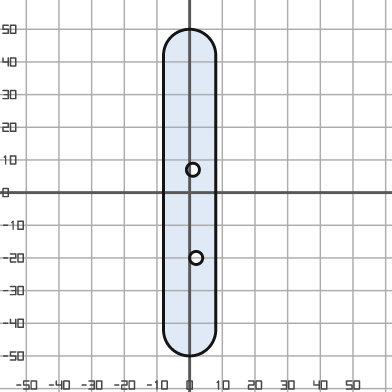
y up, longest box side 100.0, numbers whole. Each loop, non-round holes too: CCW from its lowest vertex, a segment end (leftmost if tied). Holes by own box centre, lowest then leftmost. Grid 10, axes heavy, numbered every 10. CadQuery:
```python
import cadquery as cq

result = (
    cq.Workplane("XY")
    .moveTo(-8.0, -42.0)
    .threePointArc((0.0, -50.0), (8.0, -42.0))
    .lineTo(8.0, 42.0)
    .threePointArc((0.0, 50.0), (-8.0, 42.0))
    .close()
    .moveTo(2.0, -20.0)
    .circle(2.0)
    .moveTo(1.0, 7.0)
    .circle(2.0)
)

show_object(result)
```